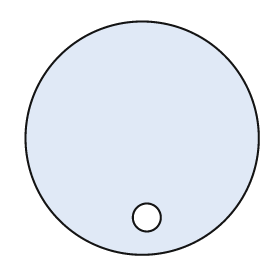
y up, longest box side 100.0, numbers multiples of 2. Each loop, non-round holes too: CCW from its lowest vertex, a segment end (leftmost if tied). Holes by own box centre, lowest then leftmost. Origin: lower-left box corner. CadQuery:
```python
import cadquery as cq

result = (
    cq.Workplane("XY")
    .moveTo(50.0, 50.0)
    .circle(50.0)
    .moveTo(52.0, 16.0)
    .circle(6.0)
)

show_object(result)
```